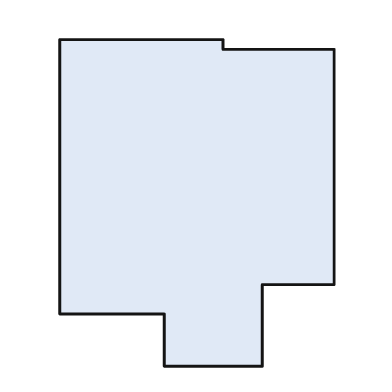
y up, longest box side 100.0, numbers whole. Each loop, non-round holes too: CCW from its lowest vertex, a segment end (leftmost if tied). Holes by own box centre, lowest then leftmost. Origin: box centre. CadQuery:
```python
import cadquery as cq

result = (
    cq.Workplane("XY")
    .moveTo(-10.0, -50.0)
    .lineTo(20.0, -50.0)
    .lineTo(20.0, -25.0)
    .lineTo(42.0, -25.0)
    .lineTo(42.0, 47.0)
    .lineTo(8.0, 47.0)
    .lineTo(8.0, 50.0)
    .lineTo(-42.0, 50.0)
    .lineTo(-42.0, -34.0)
    .lineTo(-10.0, -34.0)
    .close()
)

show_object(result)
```